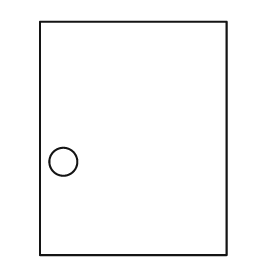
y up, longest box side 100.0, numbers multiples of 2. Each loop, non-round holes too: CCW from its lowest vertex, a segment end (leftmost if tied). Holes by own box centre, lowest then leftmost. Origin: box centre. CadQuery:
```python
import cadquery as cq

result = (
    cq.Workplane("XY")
    .moveTo(-40.0, -50.0)
    .lineTo(40.0, -50.0)
    .lineTo(40.0, 50.0)
    .lineTo(-40.0, 50.0)
    .close()
    .moveTo(-30.0, -10.0)
    .circle(6.0)
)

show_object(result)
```